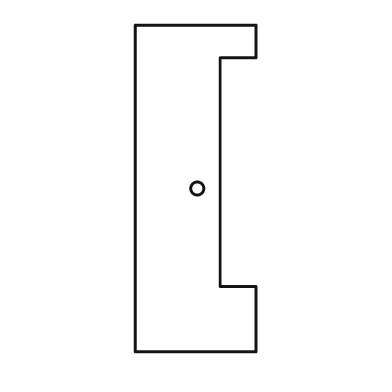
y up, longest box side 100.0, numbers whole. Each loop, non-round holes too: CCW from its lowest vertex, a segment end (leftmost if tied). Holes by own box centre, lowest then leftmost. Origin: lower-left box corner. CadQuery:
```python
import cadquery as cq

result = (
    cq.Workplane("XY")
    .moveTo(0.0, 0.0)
    .lineTo(37.0, 0.0)
    .lineTo(37.0, 20.0)
    .lineTo(26.0, 20.0)
    .lineTo(26.0, 90.0)
    .lineTo(37.0, 90.0)
    .lineTo(37.0, 100.0)
    .lineTo(0.0, 100.0)
    .close()
    .moveTo(19.0, 50.0)
    .circle(2.0)
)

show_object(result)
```